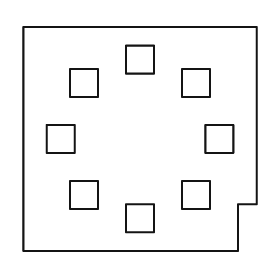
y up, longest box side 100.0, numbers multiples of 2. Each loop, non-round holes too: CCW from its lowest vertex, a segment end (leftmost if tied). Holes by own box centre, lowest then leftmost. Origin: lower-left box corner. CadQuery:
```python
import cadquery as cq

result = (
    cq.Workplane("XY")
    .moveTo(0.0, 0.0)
    .lineTo(92.0, 0.0)
    .lineTo(92.0, 20.0)
    .lineTo(100.0, 20.0)
    .lineTo(100.0, 96.0)
    .lineTo(0.0, 96.0)
    .close()
    .moveTo(44.0, 8.0)
    .lineTo(56.0, 8.0)
    .lineTo(56.0, 20.0)
    .lineTo(44.0, 20.0)
    .close()
    .moveTo(20.0, 18.0)
    .lineTo(32.0, 18.0)
    .lineTo(32.0, 30.0)
    .lineTo(20.0, 30.0)
    .close()
    .moveTo(68.0, 18.0)
    .lineTo(80.0, 18.0)
    .lineTo(80.0, 30.0)
    .lineTo(68.0, 30.0)
    .close()
    .moveTo(10.0, 42.0)
    .lineTo(22.0, 42.0)
    .lineTo(22.0, 54.0)
    .lineTo(10.0, 54.0)
    .close()
    .moveTo(78.0, 42.0)
    .lineTo(90.0, 42.0)
    .lineTo(90.0, 54.0)
    .lineTo(78.0, 54.0)
    .close()
    .moveTo(20.0, 66.0)
    .lineTo(32.0, 66.0)
    .lineTo(32.0, 78.0)
    .lineTo(20.0, 78.0)
    .close()
    .moveTo(68.0, 66.0)
    .lineTo(80.0, 66.0)
    .lineTo(80.0, 78.0)
    .lineTo(68.0, 78.0)
    .close()
    .moveTo(44.0, 76.0)
    .lineTo(56.0, 76.0)
    .lineTo(56.0, 88.0)
    .lineTo(44.0, 88.0)
    .close()
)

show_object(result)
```